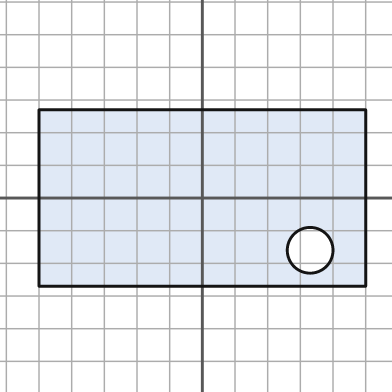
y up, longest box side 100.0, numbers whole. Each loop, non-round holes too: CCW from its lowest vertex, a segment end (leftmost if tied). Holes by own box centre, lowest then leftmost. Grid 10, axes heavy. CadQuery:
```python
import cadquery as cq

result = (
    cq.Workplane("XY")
    .moveTo(-50.0, -27.0)
    .lineTo(50.0, -27.0)
    .lineTo(50.0, 27.0)
    .lineTo(-50.0, 27.0)
    .close()
    .moveTo(33.0, -16.0)
    .circle(7.0)
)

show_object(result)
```